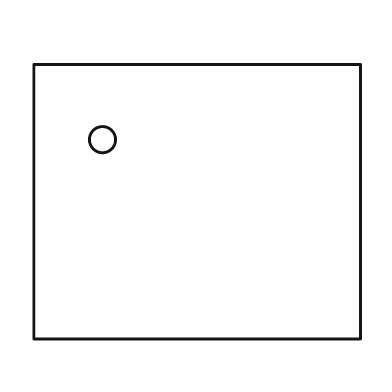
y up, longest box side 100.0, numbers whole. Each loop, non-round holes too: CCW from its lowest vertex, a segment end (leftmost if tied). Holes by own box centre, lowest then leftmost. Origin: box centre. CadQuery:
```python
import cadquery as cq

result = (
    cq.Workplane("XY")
    .moveTo(-50.0, -42.0)
    .lineTo(50.0, -42.0)
    .lineTo(50.0, 42.0)
    .lineTo(-50.0, 42.0)
    .close()
    .moveTo(-29.0, 19.0)
    .circle(4.0)
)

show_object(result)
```